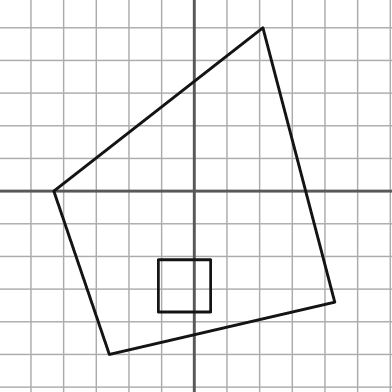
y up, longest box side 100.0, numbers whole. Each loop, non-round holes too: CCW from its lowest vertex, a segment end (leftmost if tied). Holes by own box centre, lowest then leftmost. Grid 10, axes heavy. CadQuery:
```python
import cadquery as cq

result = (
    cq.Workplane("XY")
    .moveTo(-26.0, -50.0)
    .lineTo(43.0, -34.0)
    .lineTo(21.0, 50.0)
    .lineTo(-43.0, 0.0)
    .close()
    .moveTo(-11.0, -37.0)
    .lineTo(5.0, -37.0)
    .lineTo(5.0, -21.0)
    .lineTo(-11.0, -21.0)
    .close()
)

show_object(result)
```